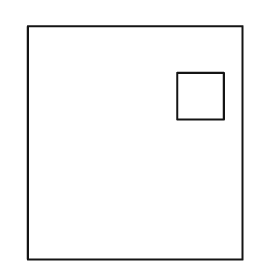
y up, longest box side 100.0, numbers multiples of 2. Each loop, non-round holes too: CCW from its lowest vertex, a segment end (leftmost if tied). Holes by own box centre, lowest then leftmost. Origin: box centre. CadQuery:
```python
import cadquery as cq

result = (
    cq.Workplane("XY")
    .moveTo(-46.0, -50.0)
    .lineTo(46.0, -50.0)
    .lineTo(46.0, 50.0)
    .lineTo(-46.0, 50.0)
    .close()
    .moveTo(18.0, 10.0)
    .lineTo(38.0, 10.0)
    .lineTo(38.0, 30.0)
    .lineTo(18.0, 30.0)
    .close()
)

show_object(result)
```